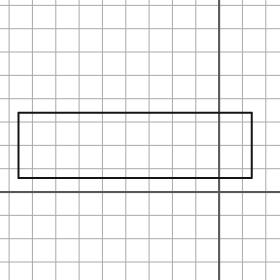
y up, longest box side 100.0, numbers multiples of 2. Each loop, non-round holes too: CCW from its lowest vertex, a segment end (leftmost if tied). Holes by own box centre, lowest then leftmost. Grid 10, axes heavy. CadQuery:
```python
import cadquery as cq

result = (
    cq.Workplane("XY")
    .moveTo(-86.0, 6.0)
    .lineTo(14.0, 6.0)
    .lineTo(14.0, 34.0)
    .lineTo(-86.0, 34.0)
    .close()
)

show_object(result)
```